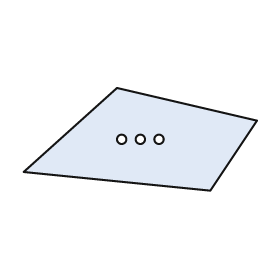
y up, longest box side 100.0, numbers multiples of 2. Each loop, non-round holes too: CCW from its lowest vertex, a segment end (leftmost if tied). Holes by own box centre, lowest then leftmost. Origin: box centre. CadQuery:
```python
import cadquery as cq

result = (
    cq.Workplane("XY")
    .moveTo(30.0, -22.0)
    .lineTo(50.0, 8.0)
    .lineTo(-10.0, 22.0)
    .lineTo(-50.0, -14.0)
    .close()
    .moveTo(-8.0, 0.0)
    .circle(2.0)
    .moveTo(0.0, 0.0)
    .circle(2.0)
    .moveTo(8.0, 0.0)
    .circle(2.0)
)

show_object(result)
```